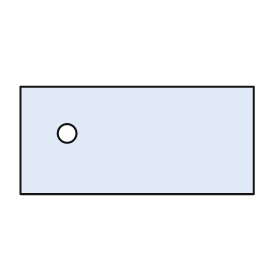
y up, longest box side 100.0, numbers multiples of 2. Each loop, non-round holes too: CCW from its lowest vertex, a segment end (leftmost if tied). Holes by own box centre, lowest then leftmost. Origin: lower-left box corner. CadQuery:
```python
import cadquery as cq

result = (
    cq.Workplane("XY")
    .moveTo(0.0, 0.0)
    .lineTo(100.0, 0.0)
    .lineTo(100.0, 46.0)
    .lineTo(0.0, 46.0)
    .close()
    .moveTo(20.0, 26.0)
    .circle(4.0)
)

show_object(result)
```